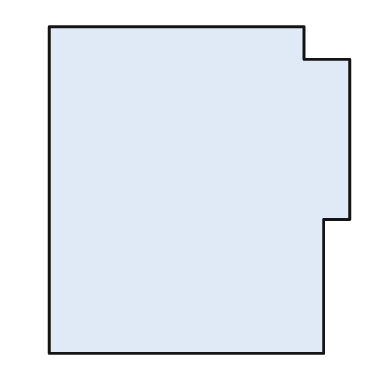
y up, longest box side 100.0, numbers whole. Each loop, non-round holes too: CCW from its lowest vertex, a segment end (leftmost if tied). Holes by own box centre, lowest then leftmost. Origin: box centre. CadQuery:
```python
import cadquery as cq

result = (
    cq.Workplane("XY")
    .moveTo(-46.0, -50.0)
    .lineTo(38.0, -50.0)
    .lineTo(38.0, -9.0)
    .lineTo(46.0, -9.0)
    .lineTo(46.0, 40.0)
    .lineTo(32.0, 40.0)
    .lineTo(32.0, 50.0)
    .lineTo(-46.0, 50.0)
    .close()
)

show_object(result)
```